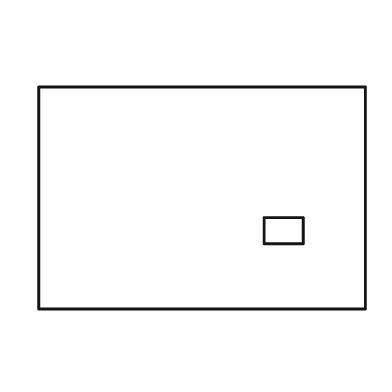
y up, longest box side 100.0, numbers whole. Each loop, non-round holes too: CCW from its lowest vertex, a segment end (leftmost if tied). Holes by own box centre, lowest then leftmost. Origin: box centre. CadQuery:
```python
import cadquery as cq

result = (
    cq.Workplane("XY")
    .moveTo(-50.0, -34.0)
    .lineTo(50.0, -34.0)
    .lineTo(50.0, 34.0)
    .lineTo(-50.0, 34.0)
    .close()
    .moveTo(19.0, -14.0)
    .lineTo(31.0, -14.0)
    .lineTo(31.0, -6.0)
    .lineTo(19.0, -6.0)
    .close()
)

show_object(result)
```